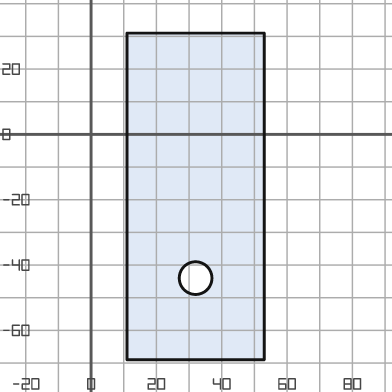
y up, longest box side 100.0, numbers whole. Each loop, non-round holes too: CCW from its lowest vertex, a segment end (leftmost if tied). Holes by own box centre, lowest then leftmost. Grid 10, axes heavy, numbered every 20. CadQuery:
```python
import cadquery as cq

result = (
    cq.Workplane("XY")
    .moveTo(11.0, -69.0)
    .lineTo(53.0, -69.0)
    .lineTo(53.0, 31.0)
    .lineTo(11.0, 31.0)
    .close()
    .moveTo(32.0, -44.0)
    .circle(5.0)
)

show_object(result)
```